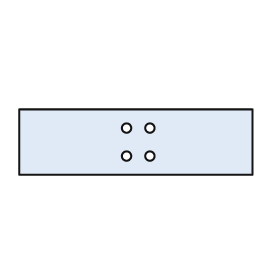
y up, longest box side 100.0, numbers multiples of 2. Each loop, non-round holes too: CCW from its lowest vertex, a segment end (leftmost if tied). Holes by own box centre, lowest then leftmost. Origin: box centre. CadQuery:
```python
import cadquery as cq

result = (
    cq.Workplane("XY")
    .moveTo(-50.0, -14.0)
    .lineTo(50.0, -14.0)
    .lineTo(50.0, 14.0)
    .lineTo(-50.0, 14.0)
    .close()
    .moveTo(-4.0, -6.0)
    .circle(2.0)
    .moveTo(6.0, -6.0)
    .circle(2.0)
    .moveTo(-4.0, 6.0)
    .circle(2.0)
    .moveTo(6.0, 6.0)
    .circle(2.0)
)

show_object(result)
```